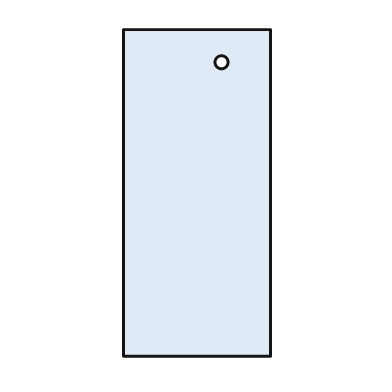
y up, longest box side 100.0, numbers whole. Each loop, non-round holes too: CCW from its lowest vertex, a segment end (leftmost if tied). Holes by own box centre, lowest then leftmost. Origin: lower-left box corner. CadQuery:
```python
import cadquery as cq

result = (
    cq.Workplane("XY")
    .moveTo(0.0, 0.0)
    .lineTo(45.0, 0.0)
    .lineTo(45.0, 100.0)
    .lineTo(0.0, 100.0)
    .close()
    .moveTo(30.0, 90.0)
    .circle(2.0)
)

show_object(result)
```